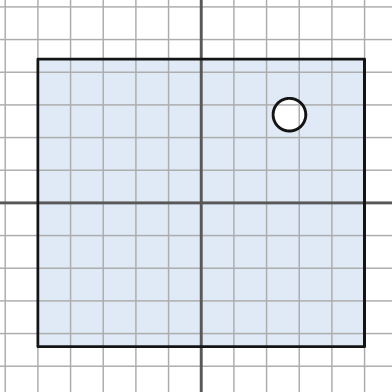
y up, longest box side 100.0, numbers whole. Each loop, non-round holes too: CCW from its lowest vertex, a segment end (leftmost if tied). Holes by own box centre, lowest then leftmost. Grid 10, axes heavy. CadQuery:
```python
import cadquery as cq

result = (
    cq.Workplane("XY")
    .moveTo(-50.0, -44.0)
    .lineTo(50.0, -44.0)
    .lineTo(50.0, 44.0)
    .lineTo(-50.0, 44.0)
    .close()
    .moveTo(27.0, 27.0)
    .circle(5.0)
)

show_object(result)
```